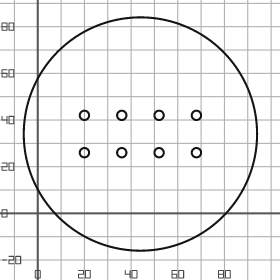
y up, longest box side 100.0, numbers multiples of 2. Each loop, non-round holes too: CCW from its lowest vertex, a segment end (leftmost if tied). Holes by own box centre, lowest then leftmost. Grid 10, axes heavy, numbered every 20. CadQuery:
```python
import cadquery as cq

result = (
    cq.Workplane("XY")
    .moveTo(44.0, 34.0)
    .circle(50.0)
    .moveTo(20.0, 26.0)
    .circle(2.0)
    .moveTo(36.0, 26.0)
    .circle(2.0)
    .moveTo(52.0, 26.0)
    .circle(2.0)
    .moveTo(68.0, 26.0)
    .circle(2.0)
    .moveTo(20.0, 42.0)
    .circle(2.0)
    .moveTo(36.0, 42.0)
    .circle(2.0)
    .moveTo(52.0, 42.0)
    .circle(2.0)
    .moveTo(68.0, 42.0)
    .circle(2.0)
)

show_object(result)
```